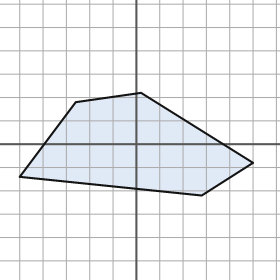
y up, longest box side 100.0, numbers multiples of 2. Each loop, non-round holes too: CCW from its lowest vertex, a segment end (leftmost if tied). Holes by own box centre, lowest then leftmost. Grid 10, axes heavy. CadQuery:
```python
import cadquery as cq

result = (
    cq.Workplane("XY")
    .moveTo(28.0, -22.0)
    .lineTo(50.0, -8.0)
    .lineTo(2.0, 22.0)
    .lineTo(-26.0, 18.0)
    .lineTo(-50.0, -14.0)
    .close()
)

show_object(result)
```